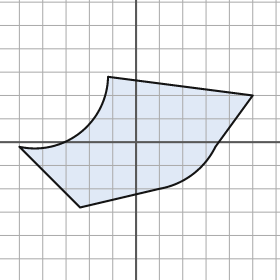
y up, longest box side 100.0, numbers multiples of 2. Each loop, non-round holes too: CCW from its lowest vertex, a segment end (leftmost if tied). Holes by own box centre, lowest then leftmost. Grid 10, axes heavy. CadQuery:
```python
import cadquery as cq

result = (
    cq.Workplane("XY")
    .moveTo(-24.0, -28.0)
    .lineTo(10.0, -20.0)
    .threePointArc((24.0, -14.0), (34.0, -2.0))
    .lineTo(50.0, 20.0)
    .lineTo(-12.0, 28.0)
    .threePointArc((-24.0, 4.0), (-50.0, -2.0))
    .close()
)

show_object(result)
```